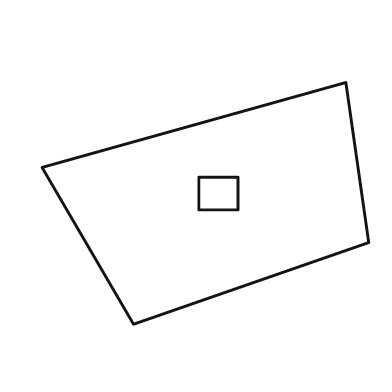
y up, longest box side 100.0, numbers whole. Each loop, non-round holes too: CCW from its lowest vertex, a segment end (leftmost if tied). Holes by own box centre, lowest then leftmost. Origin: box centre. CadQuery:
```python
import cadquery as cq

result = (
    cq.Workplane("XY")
    .moveTo(-22.0, -37.0)
    .lineTo(50.0, -12.0)
    .lineTo(43.0, 37.0)
    .lineTo(-50.0, 11.0)
    .close()
    .moveTo(-2.0, -2.0)
    .lineTo(10.0, -2.0)
    .lineTo(10.0, 8.0)
    .lineTo(-2.0, 8.0)
    .close()
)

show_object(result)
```